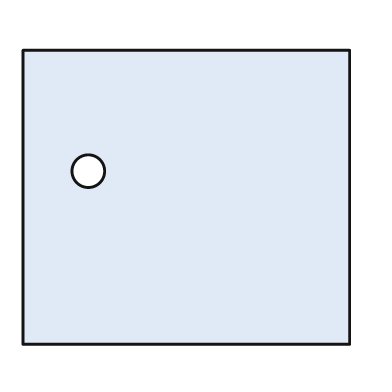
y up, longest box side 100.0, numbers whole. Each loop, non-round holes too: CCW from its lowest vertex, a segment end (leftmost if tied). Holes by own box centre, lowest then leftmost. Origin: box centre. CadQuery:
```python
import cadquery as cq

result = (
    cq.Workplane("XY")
    .moveTo(-50.0, -45.0)
    .lineTo(50.0, -45.0)
    .lineTo(50.0, 45.0)
    .lineTo(-50.0, 45.0)
    .close()
    .moveTo(-30.0, 8.0)
    .circle(5.0)
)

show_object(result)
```